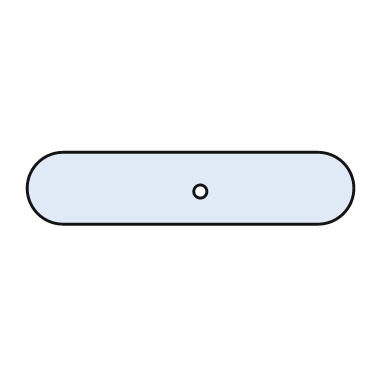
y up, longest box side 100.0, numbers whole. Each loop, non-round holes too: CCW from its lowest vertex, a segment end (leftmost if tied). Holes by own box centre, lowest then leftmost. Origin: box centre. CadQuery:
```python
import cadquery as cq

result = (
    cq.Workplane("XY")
    .moveTo(-39.0, -11.0)
    .lineTo(39.0, -11.0)
    .threePointArc((50.0, 0.0), (39.0, 11.0))
    .lineTo(-39.0, 11.0)
    .threePointArc((-50.0, 0.0), (-39.0, -11.0))
    .close()
    .moveTo(3.0, -1.0)
    .circle(2.0)
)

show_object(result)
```